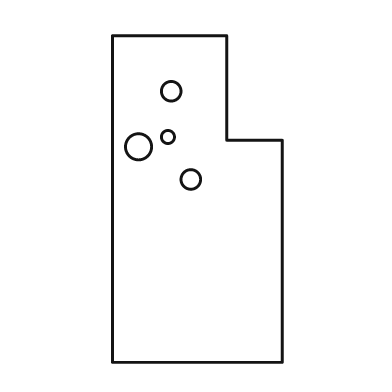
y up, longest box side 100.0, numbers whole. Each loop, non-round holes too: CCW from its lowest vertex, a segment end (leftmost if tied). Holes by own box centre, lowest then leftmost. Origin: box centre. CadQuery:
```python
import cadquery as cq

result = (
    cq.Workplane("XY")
    .moveTo(-26.0, -50.0)
    .lineTo(26.0, -50.0)
    .lineTo(26.0, 18.0)
    .lineTo(9.0, 18.0)
    .lineTo(9.0, 50.0)
    .lineTo(-26.0, 50.0)
    .close()
    .moveTo(-2.0, 6.0)
    .circle(3.0)
    .moveTo(-18.0, 16.0)
    .circle(4.0)
    .moveTo(-9.0, 19.0)
    .circle(2.0)
    .moveTo(-8.0, 33.0)
    .circle(3.0)
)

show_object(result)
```